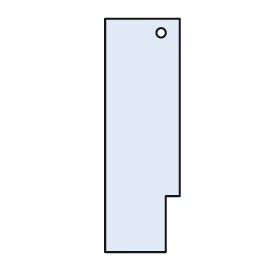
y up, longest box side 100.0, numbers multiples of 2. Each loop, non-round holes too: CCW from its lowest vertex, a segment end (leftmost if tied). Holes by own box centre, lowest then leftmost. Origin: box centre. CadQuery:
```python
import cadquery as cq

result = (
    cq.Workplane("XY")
    .moveTo(-16.0, -50.0)
    .lineTo(10.0, -50.0)
    .lineTo(10.0, -26.0)
    .lineTo(16.0, -26.0)
    .lineTo(16.0, 50.0)
    .lineTo(-16.0, 50.0)
    .close()
    .moveTo(8.0, 44.0)
    .circle(2.0)
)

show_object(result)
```